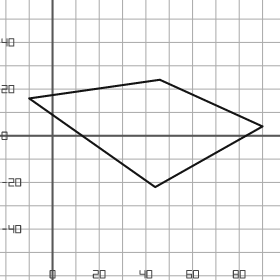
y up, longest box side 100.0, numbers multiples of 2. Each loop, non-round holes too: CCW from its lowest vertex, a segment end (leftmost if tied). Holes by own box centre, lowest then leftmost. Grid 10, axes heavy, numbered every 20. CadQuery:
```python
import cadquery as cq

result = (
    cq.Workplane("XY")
    .moveTo(44.0, -22.0)
    .lineTo(90.0, 4.0)
    .lineTo(46.0, 24.0)
    .lineTo(-10.0, 16.0)
    .close()
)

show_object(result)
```